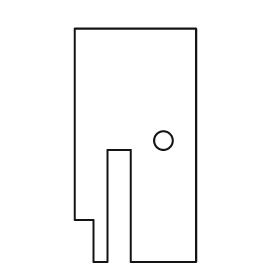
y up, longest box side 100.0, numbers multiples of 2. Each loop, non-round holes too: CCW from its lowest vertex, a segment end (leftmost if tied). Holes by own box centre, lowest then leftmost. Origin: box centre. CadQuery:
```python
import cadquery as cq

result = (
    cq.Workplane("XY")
    .moveTo(-18.0, -50.0)
    .lineTo(-12.0, -50.0)
    .lineTo(-12.0, -2.0)
    .lineTo(-2.0, -2.0)
    .lineTo(-2.0, -50.0)
    .lineTo(26.0, -50.0)
    .lineTo(26.0, 50.0)
    .lineTo(-26.0, 50.0)
    .lineTo(-26.0, -32.0)
    .lineTo(-18.0, -32.0)
    .close()
    .moveTo(12.0, 2.0)
    .circle(4.0)
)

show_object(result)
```